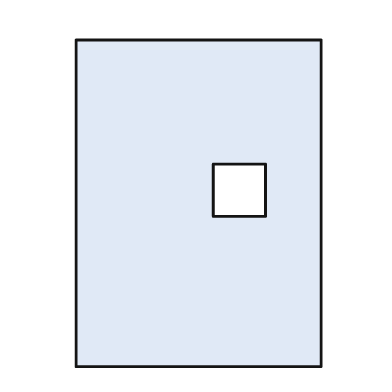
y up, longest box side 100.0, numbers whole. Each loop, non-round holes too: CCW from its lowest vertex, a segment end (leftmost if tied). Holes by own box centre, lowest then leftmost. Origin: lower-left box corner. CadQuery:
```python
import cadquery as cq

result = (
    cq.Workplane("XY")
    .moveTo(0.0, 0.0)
    .lineTo(75.0, 0.0)
    .lineTo(75.0, 100.0)
    .lineTo(0.0, 100.0)
    .close()
    .moveTo(42.0, 46.0)
    .lineTo(58.0, 46.0)
    .lineTo(58.0, 62.0)
    .lineTo(42.0, 62.0)
    .close()
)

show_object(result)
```